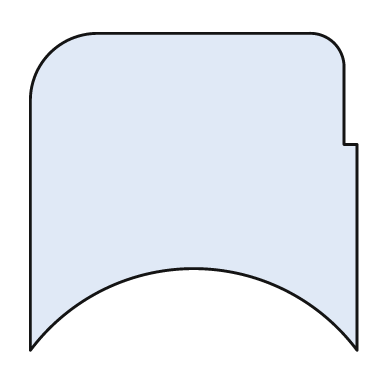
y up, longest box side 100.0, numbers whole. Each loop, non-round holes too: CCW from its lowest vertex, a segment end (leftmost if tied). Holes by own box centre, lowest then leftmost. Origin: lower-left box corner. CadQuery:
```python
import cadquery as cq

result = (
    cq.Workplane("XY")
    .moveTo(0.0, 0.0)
    .threePointArc((50.0, 25.0), (100.0, 0.0))
    .lineTo(100.0, 63.0)
    .lineTo(96.0, 63.0)
    .lineTo(96.0, 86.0)
    .threePointArc((93.0, 94.0), (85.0, 97.0))
    .lineTo(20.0, 97.0)
    .threePointArc((6.0, 91.0), (0.0, 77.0))
    .close()
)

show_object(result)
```